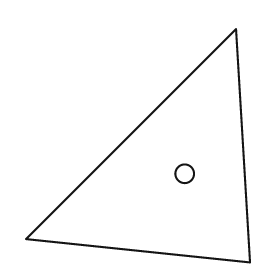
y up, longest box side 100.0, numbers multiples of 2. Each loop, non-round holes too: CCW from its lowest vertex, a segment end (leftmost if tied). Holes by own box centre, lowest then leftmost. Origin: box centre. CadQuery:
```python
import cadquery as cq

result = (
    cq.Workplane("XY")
    .moveTo(48.0, -50.0)
    .lineTo(42.0, 50.0)
    .lineTo(-48.0, -40.0)
    .close()
    .moveTo(20.0, -12.0)
    .circle(4.0)
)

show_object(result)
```